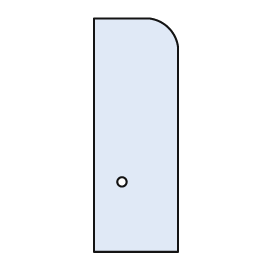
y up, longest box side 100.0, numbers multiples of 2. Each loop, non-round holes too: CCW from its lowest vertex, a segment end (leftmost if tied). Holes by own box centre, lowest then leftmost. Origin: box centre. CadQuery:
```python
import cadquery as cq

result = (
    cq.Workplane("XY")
    .moveTo(-18.0, -50.0)
    .lineTo(18.0, -50.0)
    .lineTo(18.0, 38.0)
    .threePointArc((14.0, 46.0), (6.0, 50.0))
    .lineTo(-18.0, 50.0)
    .close()
    .moveTo(-6.0, -20.0)
    .circle(2.0)
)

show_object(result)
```